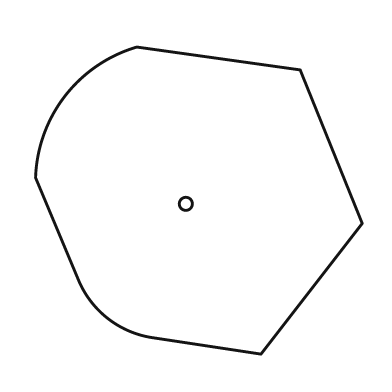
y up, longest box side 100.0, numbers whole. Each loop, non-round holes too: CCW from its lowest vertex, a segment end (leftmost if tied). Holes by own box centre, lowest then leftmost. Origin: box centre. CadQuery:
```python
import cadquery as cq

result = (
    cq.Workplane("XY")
    .moveTo(19.0, -47.0)
    .lineTo(50.0, -7.0)
    .lineTo(31.0, 40.0)
    .lineTo(-19.0, 47.0)
    .threePointArc((-41.0, 32.0), (-50.0, 7.0))
    .lineTo(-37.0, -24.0)
    .threePointArc((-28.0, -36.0), (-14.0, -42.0))
    .close()
    .moveTo(-4.0, -1.0)
    .circle(2.0)
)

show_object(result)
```